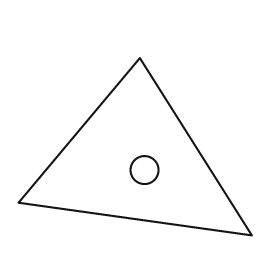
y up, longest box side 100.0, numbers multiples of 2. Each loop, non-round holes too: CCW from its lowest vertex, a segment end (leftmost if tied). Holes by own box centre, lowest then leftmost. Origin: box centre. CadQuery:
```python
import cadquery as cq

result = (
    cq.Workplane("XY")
    .moveTo(50.0, -38.0)
    .lineTo(2.0, 38.0)
    .lineTo(-50.0, -24.0)
    .close()
    .moveTo(4.0, -10.0)
    .circle(6.0)
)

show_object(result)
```